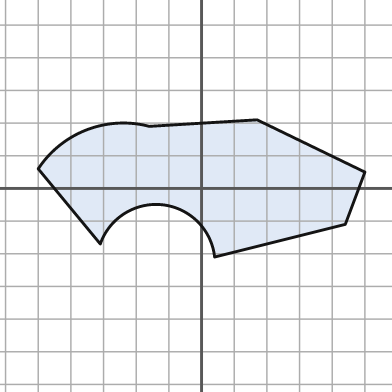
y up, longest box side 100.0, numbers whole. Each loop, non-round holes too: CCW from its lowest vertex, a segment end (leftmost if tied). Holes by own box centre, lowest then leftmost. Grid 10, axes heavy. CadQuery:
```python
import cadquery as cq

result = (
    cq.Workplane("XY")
    .moveTo(4.0, -21.0)
    .lineTo(44.0, -11.0)
    .lineTo(50.0, 5.0)
    .lineTo(17.0, 21.0)
    .lineTo(-16.0, 19.0)
    .threePointArc((-35.0, 18.0), (-50.0, 6.0))
    .lineTo(-31.0, -17.0)
    .threePointArc((-12.0, -5.0), (4.0, -21.0))
    .close()
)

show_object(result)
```